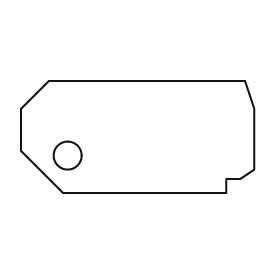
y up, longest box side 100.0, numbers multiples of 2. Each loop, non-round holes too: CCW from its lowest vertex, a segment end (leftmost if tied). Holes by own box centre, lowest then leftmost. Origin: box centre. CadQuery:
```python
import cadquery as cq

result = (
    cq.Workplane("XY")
    .moveTo(-32.0, -24.0)
    .lineTo(38.0, -24.0)
    .lineTo(38.0, -18.0)
    .lineTo(44.0, -18.0)
    .lineTo(50.0, -14.0)
    .lineTo(50.0, 12.0)
    .lineTo(46.0, 24.0)
    .lineTo(-38.0, 24.0)
    .lineTo(-50.0, 12.0)
    .lineTo(-50.0, -6.0)
    .close()
    .moveTo(-30.0, -8.0)
    .circle(6.0)
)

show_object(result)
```